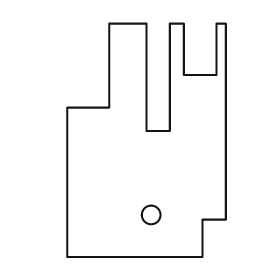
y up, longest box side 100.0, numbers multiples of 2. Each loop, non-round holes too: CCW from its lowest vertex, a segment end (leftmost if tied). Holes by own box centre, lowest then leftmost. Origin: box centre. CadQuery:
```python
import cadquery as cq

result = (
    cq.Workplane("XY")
    .moveTo(-34.0, -50.0)
    .lineTo(24.0, -50.0)
    .lineTo(24.0, -34.0)
    .lineTo(34.0, -34.0)
    .lineTo(34.0, 50.0)
    .lineTo(30.0, 50.0)
    .lineTo(30.0, 28.0)
    .lineTo(16.0, 28.0)
    .lineTo(16.0, 50.0)
    .lineTo(10.0, 50.0)
    .lineTo(10.0, 4.0)
    .lineTo(0.0, 4.0)
    .lineTo(0.0, 50.0)
    .lineTo(-16.0, 50.0)
    .lineTo(-16.0, 14.0)
    .lineTo(-34.0, 14.0)
    .close()
    .moveTo(2.0, -32.0)
    .circle(4.0)
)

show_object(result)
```